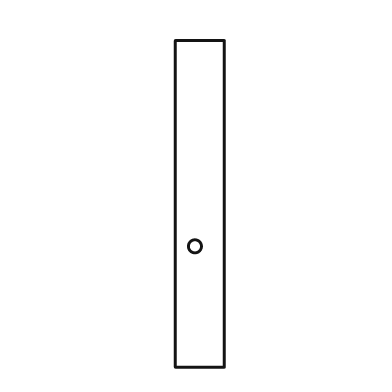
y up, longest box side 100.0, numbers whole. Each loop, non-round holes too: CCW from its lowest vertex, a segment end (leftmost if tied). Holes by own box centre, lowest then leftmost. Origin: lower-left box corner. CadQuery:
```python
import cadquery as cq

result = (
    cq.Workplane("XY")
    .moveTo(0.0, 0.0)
    .lineTo(15.0, 0.0)
    .lineTo(15.0, 100.0)
    .lineTo(0.0, 100.0)
    .close()
    .moveTo(6.0, 37.0)
    .circle(2.0)
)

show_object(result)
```